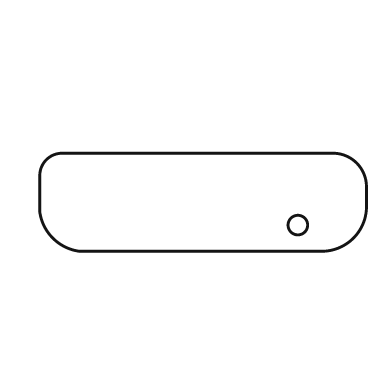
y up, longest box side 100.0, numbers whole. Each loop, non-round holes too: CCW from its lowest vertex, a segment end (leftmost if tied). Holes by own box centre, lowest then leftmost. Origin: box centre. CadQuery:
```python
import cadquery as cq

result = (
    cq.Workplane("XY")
    .moveTo(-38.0, -15.0)
    .lineTo(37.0, -15.0)
    .threePointArc((46.0, -11.0), (50.0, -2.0))
    .lineTo(50.0, 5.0)
    .threePointArc((47.0, 12.0), (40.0, 15.0))
    .lineTo(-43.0, 15.0)
    .threePointArc((-48.0, 13.0), (-50.0, 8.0))
    .lineTo(-50.0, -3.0)
    .threePointArc((-46.0, -11.0), (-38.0, -15.0))
    .close()
    .moveTo(29.0, -7.0)
    .circle(3.0)
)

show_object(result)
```